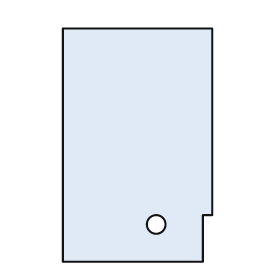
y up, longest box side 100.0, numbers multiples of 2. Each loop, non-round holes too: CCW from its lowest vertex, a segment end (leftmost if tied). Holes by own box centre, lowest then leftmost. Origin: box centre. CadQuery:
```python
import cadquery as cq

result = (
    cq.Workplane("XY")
    .moveTo(-32.0, -50.0)
    .lineTo(28.0, -50.0)
    .lineTo(28.0, -30.0)
    .lineTo(32.0, -30.0)
    .lineTo(32.0, 50.0)
    .lineTo(-32.0, 50.0)
    .close()
    .moveTo(8.0, -34.0)
    .circle(4.0)
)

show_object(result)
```